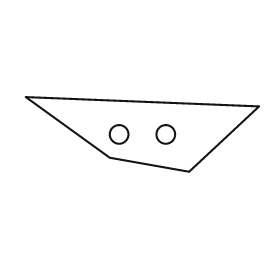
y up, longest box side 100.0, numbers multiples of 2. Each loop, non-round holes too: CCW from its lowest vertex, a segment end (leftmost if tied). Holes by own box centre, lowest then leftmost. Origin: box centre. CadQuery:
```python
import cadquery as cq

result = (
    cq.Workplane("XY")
    .moveTo(20.0, -16.0)
    .lineTo(50.0, 12.0)
    .lineTo(-50.0, 16.0)
    .lineTo(-14.0, -10.0)
    .close()
    .moveTo(-10.0, 0.0)
    .circle(4.0)
    .moveTo(10.0, 0.0)
    .circle(4.0)
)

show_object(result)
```